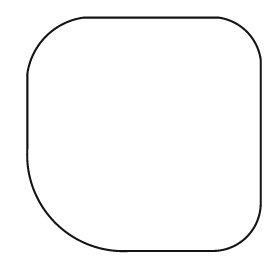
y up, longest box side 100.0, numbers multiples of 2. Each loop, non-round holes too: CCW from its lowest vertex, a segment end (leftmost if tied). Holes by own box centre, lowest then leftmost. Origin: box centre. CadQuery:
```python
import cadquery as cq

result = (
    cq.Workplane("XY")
    .moveTo(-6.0, -50.0)
    .lineTo(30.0, -50.0)
    .threePointArc((44.0, -44.0), (50.0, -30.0))
    .lineTo(50.0, 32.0)
    .threePointArc((44.0, 44.0), (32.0, 50.0))
    .lineTo(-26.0, 50.0)
    .threePointArc((-42.0, 42.0), (-50.0, 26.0))
    .lineTo(-50.0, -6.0)
    .threePointArc((-38.0, -38.0), (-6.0, -50.0))
    .close()
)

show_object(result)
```